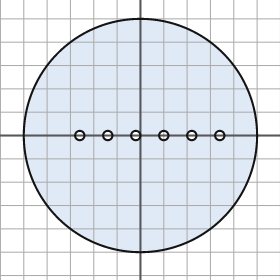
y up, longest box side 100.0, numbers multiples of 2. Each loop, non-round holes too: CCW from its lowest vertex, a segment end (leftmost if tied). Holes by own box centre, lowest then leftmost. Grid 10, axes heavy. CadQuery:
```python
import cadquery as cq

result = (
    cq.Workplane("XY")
    .moveTo(0.0, 0.0)
    .circle(50.0)
    .moveTo(-26.0, 0.0)
    .circle(2.0)
    .moveTo(-14.0, 0.0)
    .circle(2.0)
    .moveTo(-2.0, 0.0)
    .circle(2.0)
    .moveTo(10.0, 0.0)
    .circle(2.0)
    .moveTo(22.0, 0.0)
    .circle(2.0)
    .moveTo(34.0, 0.0)
    .circle(2.0)
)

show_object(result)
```